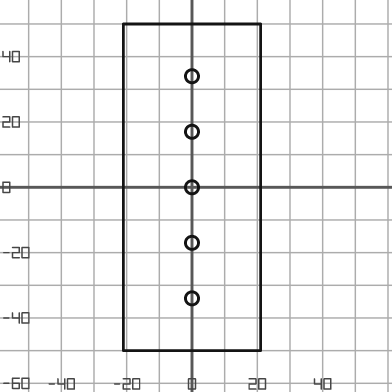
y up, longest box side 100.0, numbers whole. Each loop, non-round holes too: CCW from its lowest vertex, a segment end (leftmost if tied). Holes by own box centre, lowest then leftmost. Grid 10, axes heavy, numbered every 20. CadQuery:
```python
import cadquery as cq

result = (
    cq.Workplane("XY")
    .moveTo(-21.0, -50.0)
    .lineTo(21.0, -50.0)
    .lineTo(21.0, 50.0)
    .lineTo(-21.0, 50.0)
    .close()
    .moveTo(0.0, -34.0)
    .circle(2.0)
    .moveTo(0.0, -17.0)
    .circle(2.0)
    .moveTo(0.0, 0.0)
    .circle(2.0)
    .moveTo(0.0, 17.0)
    .circle(2.0)
    .moveTo(0.0, 34.0)
    .circle(2.0)
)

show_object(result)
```